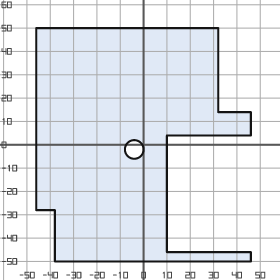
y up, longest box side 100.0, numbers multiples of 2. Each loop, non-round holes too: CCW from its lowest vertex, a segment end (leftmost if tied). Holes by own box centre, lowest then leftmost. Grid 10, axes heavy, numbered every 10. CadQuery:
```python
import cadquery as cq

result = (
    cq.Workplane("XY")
    .moveTo(-38.0, -50.0)
    .lineTo(46.0, -50.0)
    .lineTo(46.0, -46.0)
    .lineTo(10.0, -46.0)
    .lineTo(10.0, 4.0)
    .lineTo(46.0, 4.0)
    .lineTo(46.0, 14.0)
    .lineTo(32.0, 14.0)
    .lineTo(32.0, 50.0)
    .lineTo(-46.0, 50.0)
    .lineTo(-46.0, -28.0)
    .lineTo(-38.0, -28.0)
    .close()
    .moveTo(-4.0, -2.0)
    .circle(4.0)
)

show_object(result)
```